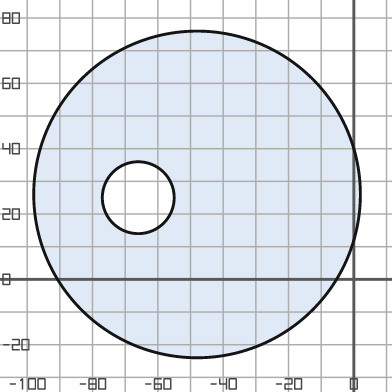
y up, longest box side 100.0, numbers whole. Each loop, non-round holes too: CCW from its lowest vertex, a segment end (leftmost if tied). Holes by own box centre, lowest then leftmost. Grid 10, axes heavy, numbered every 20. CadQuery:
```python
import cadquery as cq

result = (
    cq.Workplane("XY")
    .moveTo(-48.0, 26.0)
    .circle(50.0)
    .moveTo(-66.0, 25.0)
    .circle(11.0)
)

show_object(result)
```